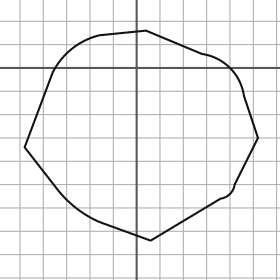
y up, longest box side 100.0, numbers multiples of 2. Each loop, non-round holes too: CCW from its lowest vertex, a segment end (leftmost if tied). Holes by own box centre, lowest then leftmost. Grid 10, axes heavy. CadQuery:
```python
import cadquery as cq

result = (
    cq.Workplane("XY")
    .moveTo(6.0, -74.0)
    .lineTo(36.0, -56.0)
    .threePointArc((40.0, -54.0), (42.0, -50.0))
    .lineTo(52.0, -30.0)
    .lineTo(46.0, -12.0)
    .threePointArc((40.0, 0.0), (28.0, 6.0))
    .lineTo(4.0, 16.0)
    .lineTo(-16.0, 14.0)
    .threePointArc((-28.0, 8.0), (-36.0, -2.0))
    .lineTo(-48.0, -34.0)
    .lineTo(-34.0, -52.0)
    .threePointArc((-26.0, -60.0), (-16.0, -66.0))
    .close()
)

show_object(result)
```